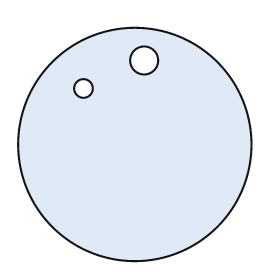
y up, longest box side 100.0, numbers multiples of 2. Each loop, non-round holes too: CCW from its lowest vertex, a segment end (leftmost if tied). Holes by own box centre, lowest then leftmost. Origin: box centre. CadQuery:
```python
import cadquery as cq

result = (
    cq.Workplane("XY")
    .moveTo(0.0, 0.0)
    .circle(50.0)
    .moveTo(-22.0, 24.0)
    .circle(4.0)
    .moveTo(4.0, 36.0)
    .circle(6.0)
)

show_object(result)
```